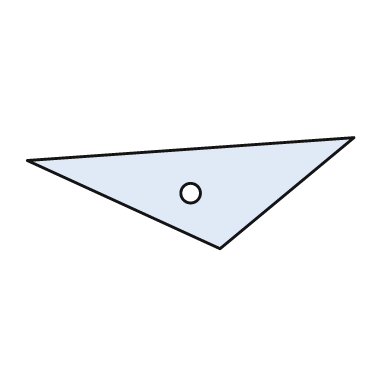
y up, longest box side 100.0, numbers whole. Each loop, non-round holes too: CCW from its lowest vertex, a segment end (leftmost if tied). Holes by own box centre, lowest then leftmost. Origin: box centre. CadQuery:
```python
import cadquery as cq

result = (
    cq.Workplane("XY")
    .moveTo(9.0, -17.0)
    .lineTo(50.0, 17.0)
    .lineTo(-50.0, 10.0)
    .close()
    .moveTo(0.0, 0.0)
    .circle(3.0)
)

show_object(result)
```